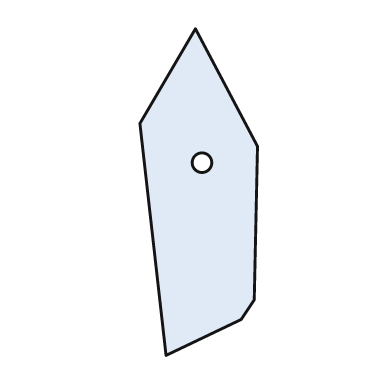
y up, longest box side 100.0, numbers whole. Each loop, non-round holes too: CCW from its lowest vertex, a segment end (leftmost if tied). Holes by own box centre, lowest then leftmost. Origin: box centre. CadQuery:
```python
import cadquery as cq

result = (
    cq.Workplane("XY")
    .moveTo(-10.0, -50.0)
    .lineTo(13.0, -39.0)
    .lineTo(17.0, -33.0)
    .lineTo(18.0, 14.0)
    .lineTo(-1.0, 50.0)
    .lineTo(-18.0, 21.0)
    .close()
    .moveTo(1.0, 9.0)
    .circle(3.0)
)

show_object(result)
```